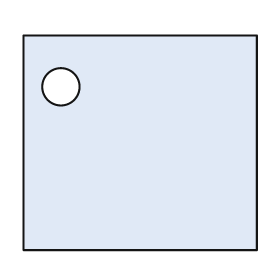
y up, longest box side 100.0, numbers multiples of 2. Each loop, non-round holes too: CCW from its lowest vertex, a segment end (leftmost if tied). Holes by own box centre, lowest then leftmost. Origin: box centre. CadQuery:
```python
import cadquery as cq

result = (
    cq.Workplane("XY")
    .moveTo(-50.0, -46.0)
    .lineTo(50.0, -46.0)
    .lineTo(50.0, 46.0)
    .lineTo(-50.0, 46.0)
    .close()
    .moveTo(-34.0, 24.0)
    .circle(8.0)
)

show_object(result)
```